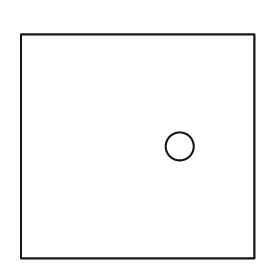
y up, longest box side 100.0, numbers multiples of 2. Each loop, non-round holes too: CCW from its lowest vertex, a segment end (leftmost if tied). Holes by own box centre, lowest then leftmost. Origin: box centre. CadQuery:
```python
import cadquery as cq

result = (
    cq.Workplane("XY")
    .moveTo(-50.0, -48.0)
    .lineTo(50.0, -48.0)
    .lineTo(50.0, 48.0)
    .lineTo(-50.0, 48.0)
    .close()
    .moveTo(18.0, 0.0)
    .circle(6.0)
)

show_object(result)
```